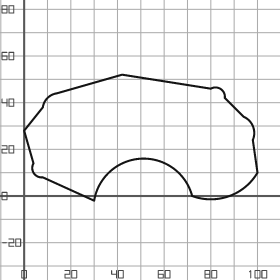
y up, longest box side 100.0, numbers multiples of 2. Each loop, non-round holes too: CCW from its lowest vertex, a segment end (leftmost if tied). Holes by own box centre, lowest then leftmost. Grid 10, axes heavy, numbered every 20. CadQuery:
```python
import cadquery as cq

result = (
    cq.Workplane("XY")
    .moveTo(30.0, -2.0)
    .threePointArc((50.0, 16.0), (72.0, 0.0))
    .threePointArc((88.0, 0.0), (100.0, 10.0))
    .lineTo(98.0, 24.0)
    .threePointArc((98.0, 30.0), (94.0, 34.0))
    .lineTo(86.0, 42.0)
    .threePointArc((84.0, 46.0), (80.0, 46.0))
    .lineTo(42.0, 52.0)
    .lineTo(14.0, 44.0)
    .threePointArc((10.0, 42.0), (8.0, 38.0))
    .lineTo(0.0, 28.0)
    .lineTo(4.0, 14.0)
    .threePointArc((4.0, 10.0), (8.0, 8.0))
    .close()
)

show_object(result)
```